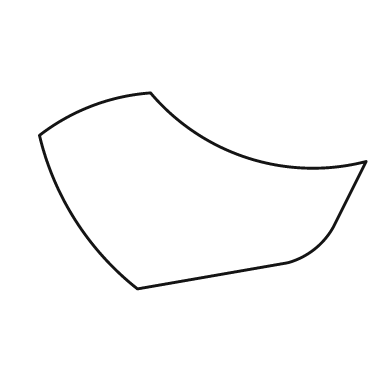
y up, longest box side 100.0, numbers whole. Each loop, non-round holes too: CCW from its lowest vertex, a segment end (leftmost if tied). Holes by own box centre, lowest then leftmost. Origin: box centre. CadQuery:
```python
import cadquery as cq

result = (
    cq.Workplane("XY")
    .moveTo(-20.0, -30.0)
    .lineTo(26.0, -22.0)
    .threePointArc((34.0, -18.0), (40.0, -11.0))
    .lineTo(50.0, 9.0)
    .threePointArc((14.0, 10.0), (-16.0, 30.0))
    .threePointArc((-34.0, 26.0), (-50.0, 17.0))
    .threePointArc((-39.0, -9.0), (-20.0, -30.0))
    .close()
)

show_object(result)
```